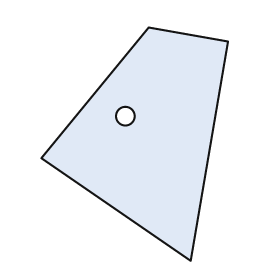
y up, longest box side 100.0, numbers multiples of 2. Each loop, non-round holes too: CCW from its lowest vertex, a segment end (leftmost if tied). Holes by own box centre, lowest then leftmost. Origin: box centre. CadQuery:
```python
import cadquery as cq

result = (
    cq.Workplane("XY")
    .moveTo(24.0, -50.0)
    .lineTo(40.0, 44.0)
    .lineTo(6.0, 50.0)
    .lineTo(-40.0, -6.0)
    .close()
    .moveTo(-4.0, 12.0)
    .circle(4.0)
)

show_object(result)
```